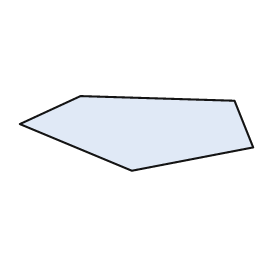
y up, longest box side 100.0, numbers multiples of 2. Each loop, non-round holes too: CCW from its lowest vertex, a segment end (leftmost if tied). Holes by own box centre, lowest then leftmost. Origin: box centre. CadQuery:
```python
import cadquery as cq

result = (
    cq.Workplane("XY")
    .moveTo(-2.0, -16.0)
    .lineTo(50.0, -6.0)
    .lineTo(42.0, 14.0)
    .lineTo(-24.0, 16.0)
    .lineTo(-50.0, 4.0)
    .close()
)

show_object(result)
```